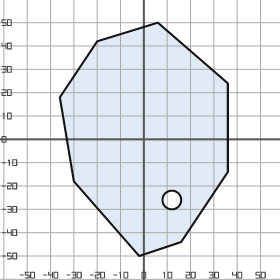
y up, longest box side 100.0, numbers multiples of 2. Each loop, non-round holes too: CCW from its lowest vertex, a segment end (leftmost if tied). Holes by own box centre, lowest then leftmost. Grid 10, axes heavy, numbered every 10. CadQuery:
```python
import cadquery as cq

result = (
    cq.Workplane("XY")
    .moveTo(-2.0, -50.0)
    .lineTo(16.0, -44.0)
    .lineTo(36.0, -14.0)
    .lineTo(36.0, 24.0)
    .lineTo(6.0, 50.0)
    .lineTo(-20.0, 42.0)
    .lineTo(-36.0, 18.0)
    .lineTo(-30.0, -18.0)
    .close()
    .moveTo(12.0, -26.0)
    .circle(4.0)
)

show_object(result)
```